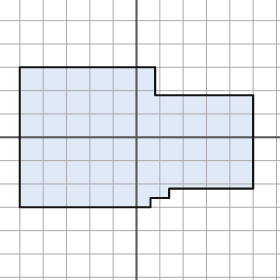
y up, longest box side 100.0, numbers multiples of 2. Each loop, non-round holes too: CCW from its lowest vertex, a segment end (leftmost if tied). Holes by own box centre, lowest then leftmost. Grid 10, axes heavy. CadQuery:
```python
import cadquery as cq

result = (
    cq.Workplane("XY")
    .moveTo(-50.0, -30.0)
    .lineTo(6.0, -30.0)
    .lineTo(6.0, -26.0)
    .lineTo(14.0, -26.0)
    .lineTo(14.0, -22.0)
    .lineTo(50.0, -22.0)
    .lineTo(50.0, 18.0)
    .lineTo(8.0, 18.0)
    .lineTo(8.0, 30.0)
    .lineTo(-50.0, 30.0)
    .close()
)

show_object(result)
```